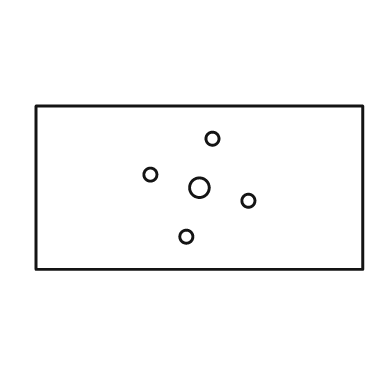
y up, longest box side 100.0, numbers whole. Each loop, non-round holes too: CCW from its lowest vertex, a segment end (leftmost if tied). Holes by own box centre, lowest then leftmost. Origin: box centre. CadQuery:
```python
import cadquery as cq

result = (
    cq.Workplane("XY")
    .moveTo(-50.0, -25.0)
    .lineTo(50.0, -25.0)
    .lineTo(50.0, 25.0)
    .lineTo(-50.0, 25.0)
    .close()
    .moveTo(-4.0, -15.0)
    .circle(2.0)
    .moveTo(15.0, -4.0)
    .circle(2.0)
    .moveTo(0.0, 0.0)
    .circle(3.0)
    .moveTo(-15.0, 4.0)
    .circle(2.0)
    .moveTo(4.0, 15.0)
    .circle(2.0)
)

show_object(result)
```